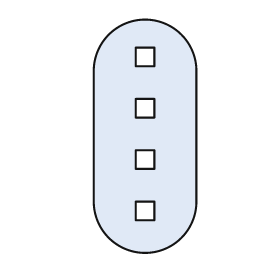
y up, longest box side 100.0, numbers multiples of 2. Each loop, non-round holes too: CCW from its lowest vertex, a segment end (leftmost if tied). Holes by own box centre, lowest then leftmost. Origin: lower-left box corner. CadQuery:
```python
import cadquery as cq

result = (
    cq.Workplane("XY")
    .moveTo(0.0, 22.0)
    .threePointArc((22.0, 0.0), (44.0, 22.0))
    .lineTo(44.0, 78.0)
    .threePointArc((22.0, 100.0), (0.0, 78.0))
    .close()
    .moveTo(18.0, 14.0)
    .lineTo(26.0, 14.0)
    .lineTo(26.0, 22.0)
    .lineTo(18.0, 22.0)
    .close()
    .moveTo(18.0, 36.0)
    .lineTo(26.0, 36.0)
    .lineTo(26.0, 44.0)
    .lineTo(18.0, 44.0)
    .close()
    .moveTo(18.0, 58.0)
    .lineTo(26.0, 58.0)
    .lineTo(26.0, 66.0)
    .lineTo(18.0, 66.0)
    .close()
    .moveTo(18.0, 80.0)
    .lineTo(26.0, 80.0)
    .lineTo(26.0, 88.0)
    .lineTo(18.0, 88.0)
    .close()
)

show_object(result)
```